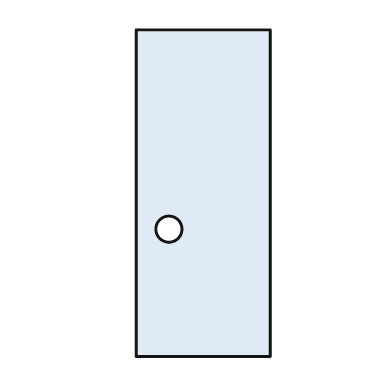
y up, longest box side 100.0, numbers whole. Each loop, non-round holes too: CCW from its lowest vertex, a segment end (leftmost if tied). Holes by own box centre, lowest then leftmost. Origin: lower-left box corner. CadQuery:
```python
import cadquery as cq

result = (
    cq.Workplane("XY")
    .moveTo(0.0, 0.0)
    .lineTo(41.0, 0.0)
    .lineTo(41.0, 100.0)
    .lineTo(0.0, 100.0)
    .close()
    .moveTo(10.0, 39.0)
    .circle(4.0)
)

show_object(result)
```